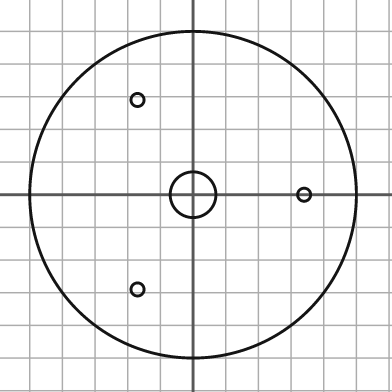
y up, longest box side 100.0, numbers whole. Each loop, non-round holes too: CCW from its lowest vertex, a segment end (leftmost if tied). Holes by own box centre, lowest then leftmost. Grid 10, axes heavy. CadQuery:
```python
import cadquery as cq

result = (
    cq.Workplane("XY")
    .moveTo(0.0, 0.0)
    .circle(50.0)
    .moveTo(-17.0, -29.0)
    .circle(2.0)
    .moveTo(0.0, 0.0)
    .circle(7.0)
    .moveTo(34.0, 0.0)
    .circle(2.0)
    .moveTo(-17.0, 29.0)
    .circle(2.0)
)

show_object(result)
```